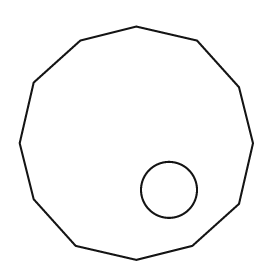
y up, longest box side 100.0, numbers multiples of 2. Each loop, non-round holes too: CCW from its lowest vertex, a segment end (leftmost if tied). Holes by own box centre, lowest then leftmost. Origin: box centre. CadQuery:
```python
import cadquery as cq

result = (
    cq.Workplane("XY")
    .moveTo(0.0, -50.0)
    .lineTo(24.0, -44.0)
    .lineTo(44.0, -26.0)
    .lineTo(50.0, 0.0)
    .lineTo(44.0, 24.0)
    .lineTo(26.0, 44.0)
    .lineTo(0.0, 50.0)
    .lineTo(-24.0, 44.0)
    .lineTo(-44.0, 26.0)
    .lineTo(-50.0, 0.0)
    .lineTo(-44.0, -24.0)
    .lineTo(-26.0, -44.0)
    .close()
    .moveTo(14.0, -20.0)
    .circle(12.0)
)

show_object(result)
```